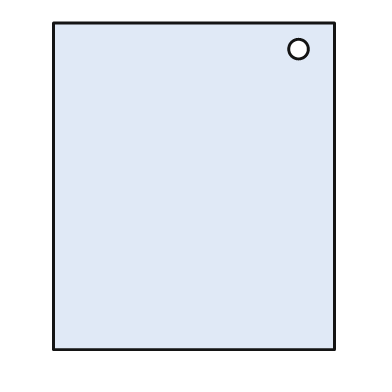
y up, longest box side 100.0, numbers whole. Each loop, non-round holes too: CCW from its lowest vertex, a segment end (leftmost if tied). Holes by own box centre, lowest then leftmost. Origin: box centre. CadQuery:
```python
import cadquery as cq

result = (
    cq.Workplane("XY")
    .moveTo(-43.0, -50.0)
    .lineTo(43.0, -50.0)
    .lineTo(43.0, 50.0)
    .lineTo(-43.0, 50.0)
    .close()
    .moveTo(32.0, 42.0)
    .circle(3.0)
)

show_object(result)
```